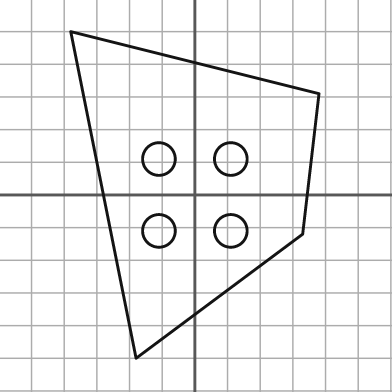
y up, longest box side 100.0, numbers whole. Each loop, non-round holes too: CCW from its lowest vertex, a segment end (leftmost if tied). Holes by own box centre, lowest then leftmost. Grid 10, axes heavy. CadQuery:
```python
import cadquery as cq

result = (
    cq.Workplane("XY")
    .moveTo(-18.0, -50.0)
    .lineTo(33.0, -12.0)
    .lineTo(38.0, 31.0)
    .lineTo(-38.0, 50.0)
    .close()
    .moveTo(-11.0, -11.0)
    .circle(5.0)
    .moveTo(11.0, -11.0)
    .circle(5.0)
    .moveTo(-11.0, 11.0)
    .circle(5.0)
    .moveTo(11.0, 11.0)
    .circle(5.0)
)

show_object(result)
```